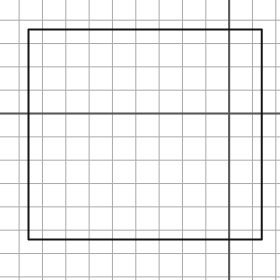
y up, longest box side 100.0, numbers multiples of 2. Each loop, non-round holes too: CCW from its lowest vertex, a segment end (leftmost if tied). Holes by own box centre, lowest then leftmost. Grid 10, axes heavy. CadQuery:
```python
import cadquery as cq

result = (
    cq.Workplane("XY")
    .moveTo(-86.0, -54.0)
    .lineTo(14.0, -54.0)
    .lineTo(14.0, 36.0)
    .lineTo(-86.0, 36.0)
    .close()
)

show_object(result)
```